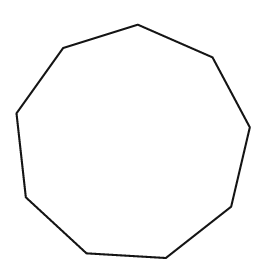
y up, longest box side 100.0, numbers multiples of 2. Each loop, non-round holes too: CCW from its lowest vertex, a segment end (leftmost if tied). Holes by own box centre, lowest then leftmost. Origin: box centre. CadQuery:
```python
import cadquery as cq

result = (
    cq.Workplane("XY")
    .moveTo(14.0, -50.0)
    .lineTo(42.0, -28.0)
    .lineTo(50.0, 6.0)
    .lineTo(34.0, 36.0)
    .lineTo(2.0, 50.0)
    .lineTo(-30.0, 40.0)
    .lineTo(-50.0, 12.0)
    .lineTo(-46.0, -24.0)
    .lineTo(-20.0, -48.0)
    .close()
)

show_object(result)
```